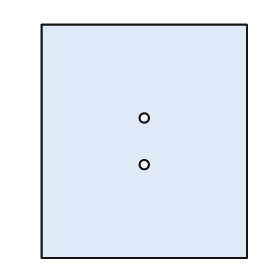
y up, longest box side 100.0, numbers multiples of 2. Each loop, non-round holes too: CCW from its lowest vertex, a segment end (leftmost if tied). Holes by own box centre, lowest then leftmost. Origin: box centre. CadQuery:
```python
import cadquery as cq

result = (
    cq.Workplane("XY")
    .moveTo(-44.0, -50.0)
    .lineTo(44.0, -50.0)
    .lineTo(44.0, 50.0)
    .lineTo(-44.0, 50.0)
    .close()
    .moveTo(0.0, -10.0)
    .circle(2.0)
    .moveTo(0.0, 10.0)
    .circle(2.0)
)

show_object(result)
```